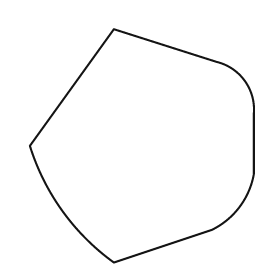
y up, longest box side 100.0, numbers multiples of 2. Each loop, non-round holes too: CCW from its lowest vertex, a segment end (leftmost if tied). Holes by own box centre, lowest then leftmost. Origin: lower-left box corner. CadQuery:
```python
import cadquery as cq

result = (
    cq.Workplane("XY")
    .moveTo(36.0, 0.0)
    .lineTo(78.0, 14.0)
    .threePointArc((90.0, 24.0), (96.0, 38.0))
    .lineTo(96.0, 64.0)
    .threePointArc((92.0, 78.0), (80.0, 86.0))
    .lineTo(36.0, 100.0)
    .lineTo(0.0, 50.0)
    .threePointArc((14.0, 22.0), (36.0, 0.0))
    .close()
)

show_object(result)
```